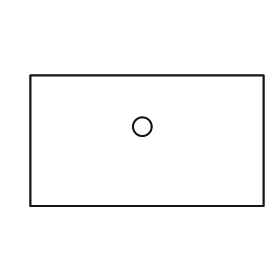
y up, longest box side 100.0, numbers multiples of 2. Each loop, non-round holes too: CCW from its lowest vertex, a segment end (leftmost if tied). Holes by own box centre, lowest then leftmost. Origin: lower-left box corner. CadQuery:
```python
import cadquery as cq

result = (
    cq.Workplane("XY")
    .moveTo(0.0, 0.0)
    .lineTo(100.0, 0.0)
    .lineTo(100.0, 56.0)
    .lineTo(0.0, 56.0)
    .close()
    .moveTo(48.0, 34.0)
    .circle(4.0)
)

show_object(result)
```